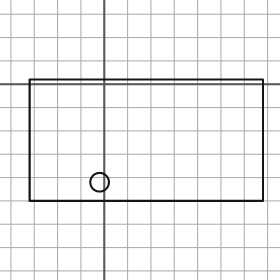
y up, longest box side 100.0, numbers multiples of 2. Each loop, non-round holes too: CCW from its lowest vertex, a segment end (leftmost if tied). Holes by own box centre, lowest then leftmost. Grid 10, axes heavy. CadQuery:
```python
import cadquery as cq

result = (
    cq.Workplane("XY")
    .moveTo(-32.0, -50.0)
    .lineTo(68.0, -50.0)
    .lineTo(68.0, 2.0)
    .lineTo(-32.0, 2.0)
    .close()
    .moveTo(-2.0, -42.0)
    .circle(4.0)
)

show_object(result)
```